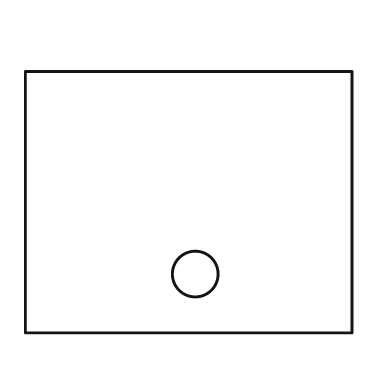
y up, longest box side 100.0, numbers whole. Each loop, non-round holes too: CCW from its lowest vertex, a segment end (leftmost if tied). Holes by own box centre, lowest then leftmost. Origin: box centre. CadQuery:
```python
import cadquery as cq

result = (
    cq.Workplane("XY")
    .moveTo(-50.0, -40.0)
    .lineTo(50.0, -40.0)
    .lineTo(50.0, 40.0)
    .lineTo(-50.0, 40.0)
    .close()
    .moveTo(2.0, -22.0)
    .circle(7.0)
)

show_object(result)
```